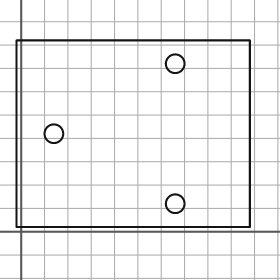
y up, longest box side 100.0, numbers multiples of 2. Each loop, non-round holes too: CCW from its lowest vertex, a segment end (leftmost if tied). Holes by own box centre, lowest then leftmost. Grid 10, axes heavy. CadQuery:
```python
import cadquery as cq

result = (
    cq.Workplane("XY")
    .moveTo(-2.0, 2.0)
    .lineTo(98.0, 2.0)
    .lineTo(98.0, 82.0)
    .lineTo(-2.0, 82.0)
    .close()
    .moveTo(66.0, 12.0)
    .circle(4.0)
    .moveTo(14.0, 42.0)
    .circle(4.0)
    .moveTo(66.0, 72.0)
    .circle(4.0)
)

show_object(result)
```